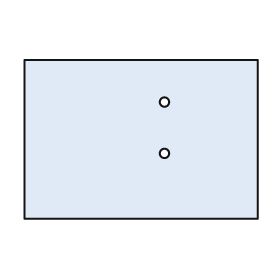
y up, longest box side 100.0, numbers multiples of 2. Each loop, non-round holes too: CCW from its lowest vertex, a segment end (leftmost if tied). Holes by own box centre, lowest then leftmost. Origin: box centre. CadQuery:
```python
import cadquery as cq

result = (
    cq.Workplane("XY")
    .moveTo(-50.0, -34.0)
    .lineTo(50.0, -34.0)
    .lineTo(50.0, 34.0)
    .lineTo(-50.0, 34.0)
    .close()
    .moveTo(10.0, -6.0)
    .circle(2.0)
    .moveTo(10.0, 16.0)
    .circle(2.0)
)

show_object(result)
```